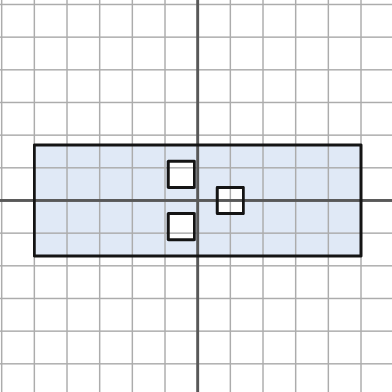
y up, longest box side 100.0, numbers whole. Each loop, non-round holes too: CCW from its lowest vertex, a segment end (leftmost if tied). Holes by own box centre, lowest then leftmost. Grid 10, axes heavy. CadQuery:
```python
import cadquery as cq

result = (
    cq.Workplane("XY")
    .moveTo(-50.0, -17.0)
    .lineTo(50.0, -17.0)
    .lineTo(50.0, 17.0)
    .lineTo(-50.0, 17.0)
    .close()
    .moveTo(-9.0, -12.0)
    .lineTo(-1.0, -12.0)
    .lineTo(-1.0, -4.0)
    .lineTo(-9.0, -4.0)
    .close()
    .moveTo(6.0, -4.0)
    .lineTo(14.0, -4.0)
    .lineTo(14.0, 4.0)
    .lineTo(6.0, 4.0)
    .close()
    .moveTo(-9.0, 4.0)
    .lineTo(-1.0, 4.0)
    .lineTo(-1.0, 12.0)
    .lineTo(-9.0, 12.0)
    .close()
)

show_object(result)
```